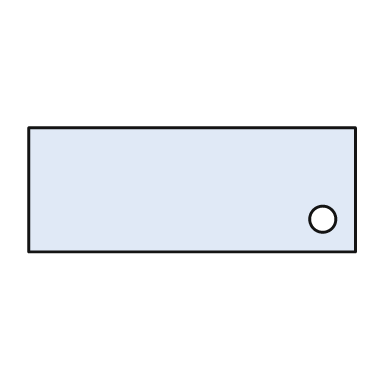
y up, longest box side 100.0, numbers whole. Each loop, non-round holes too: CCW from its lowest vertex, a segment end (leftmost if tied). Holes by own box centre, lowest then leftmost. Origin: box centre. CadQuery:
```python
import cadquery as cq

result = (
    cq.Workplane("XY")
    .moveTo(-50.0, -19.0)
    .lineTo(50.0, -19.0)
    .lineTo(50.0, 19.0)
    .lineTo(-50.0, 19.0)
    .close()
    .moveTo(40.0, -9.0)
    .circle(4.0)
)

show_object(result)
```